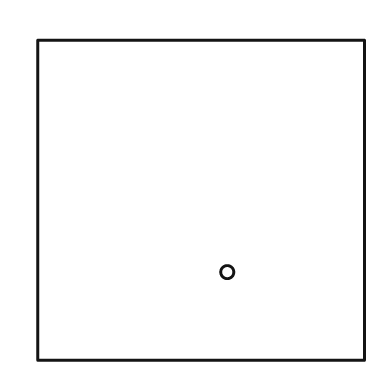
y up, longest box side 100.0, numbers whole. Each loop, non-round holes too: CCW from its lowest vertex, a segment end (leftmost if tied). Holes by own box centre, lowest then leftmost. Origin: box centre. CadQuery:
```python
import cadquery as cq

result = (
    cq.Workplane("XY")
    .moveTo(-50.0, -49.0)
    .lineTo(50.0, -49.0)
    .lineTo(50.0, 49.0)
    .lineTo(-50.0, 49.0)
    .close()
    .moveTo(8.0, -22.0)
    .circle(2.0)
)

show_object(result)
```